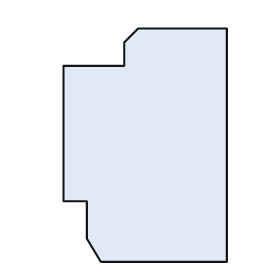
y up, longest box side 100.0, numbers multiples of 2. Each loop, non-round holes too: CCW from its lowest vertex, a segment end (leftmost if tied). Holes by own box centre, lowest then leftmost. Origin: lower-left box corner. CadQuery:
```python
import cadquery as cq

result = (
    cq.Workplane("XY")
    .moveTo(16.0, 0.0)
    .lineTo(70.0, 0.0)
    .lineTo(70.0, 100.0)
    .lineTo(32.0, 100.0)
    .lineTo(26.0, 94.0)
    .lineTo(26.0, 84.0)
    .lineTo(0.0, 84.0)
    .lineTo(0.0, 26.0)
    .lineTo(10.0, 26.0)
    .lineTo(10.0, 10.0)
    .close()
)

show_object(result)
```